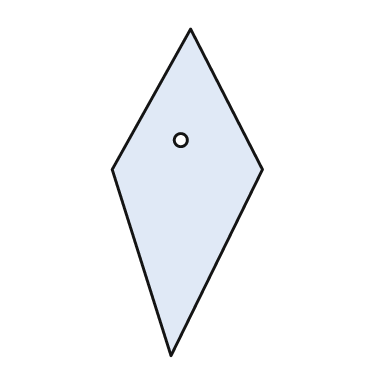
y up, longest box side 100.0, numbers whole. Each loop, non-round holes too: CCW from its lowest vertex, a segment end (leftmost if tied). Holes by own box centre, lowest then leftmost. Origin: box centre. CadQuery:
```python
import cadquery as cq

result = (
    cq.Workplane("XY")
    .moveTo(-5.0, -50.0)
    .lineTo(23.0, 7.0)
    .lineTo(1.0, 50.0)
    .lineTo(-23.0, 7.0)
    .close()
    .moveTo(-2.0, 16.0)
    .circle(2.0)
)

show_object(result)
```